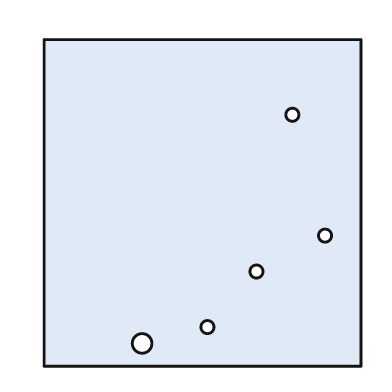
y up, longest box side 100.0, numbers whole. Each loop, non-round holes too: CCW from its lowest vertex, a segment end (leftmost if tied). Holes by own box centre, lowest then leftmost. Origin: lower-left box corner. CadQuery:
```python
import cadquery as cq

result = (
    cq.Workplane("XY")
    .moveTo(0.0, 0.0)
    .lineTo(97.0, 0.0)
    .lineTo(97.0, 100.0)
    .lineTo(0.0, 100.0)
    .close()
    .moveTo(30.0, 7.0)
    .circle(3.0)
    .moveTo(50.0, 12.0)
    .circle(2.0)
    .moveTo(65.0, 29.0)
    .circle(2.0)
    .moveTo(86.0, 40.0)
    .circle(2.0)
    .moveTo(76.0, 77.0)
    .circle(2.0)
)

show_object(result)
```